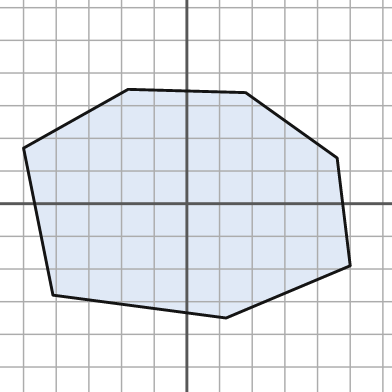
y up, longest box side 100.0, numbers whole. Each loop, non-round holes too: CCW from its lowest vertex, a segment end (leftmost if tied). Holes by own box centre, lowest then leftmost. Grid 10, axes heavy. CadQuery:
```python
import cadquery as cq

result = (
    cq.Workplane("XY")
    .moveTo(12.0, -35.0)
    .lineTo(50.0, -19.0)
    .lineTo(46.0, 14.0)
    .lineTo(18.0, 34.0)
    .lineTo(-18.0, 35.0)
    .lineTo(-50.0, 17.0)
    .lineTo(-41.0, -28.0)
    .close()
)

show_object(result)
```